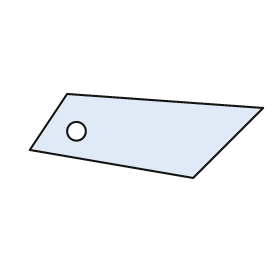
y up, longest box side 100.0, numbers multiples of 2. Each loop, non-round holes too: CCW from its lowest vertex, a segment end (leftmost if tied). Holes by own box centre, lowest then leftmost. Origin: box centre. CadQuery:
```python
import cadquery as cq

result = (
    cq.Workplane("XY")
    .moveTo(20.0, -18.0)
    .lineTo(50.0, 12.0)
    .lineTo(-34.0, 18.0)
    .lineTo(-50.0, -6.0)
    .close()
    .moveTo(-30.0, 2.0)
    .circle(4.0)
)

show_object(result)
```